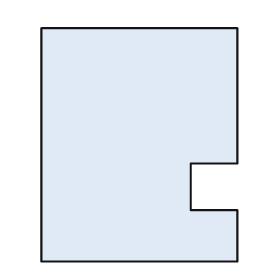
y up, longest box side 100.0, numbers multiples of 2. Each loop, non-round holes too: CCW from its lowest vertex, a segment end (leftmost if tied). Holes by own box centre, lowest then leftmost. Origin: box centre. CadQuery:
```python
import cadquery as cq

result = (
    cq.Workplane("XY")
    .moveTo(-42.0, -50.0)
    .lineTo(42.0, -50.0)
    .lineTo(42.0, -28.0)
    .lineTo(22.0, -28.0)
    .lineTo(22.0, -8.0)
    .lineTo(42.0, -8.0)
    .lineTo(42.0, 50.0)
    .lineTo(-42.0, 50.0)
    .close()
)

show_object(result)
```